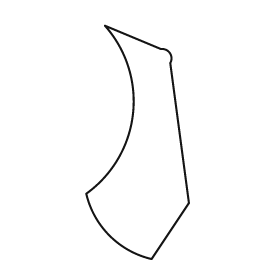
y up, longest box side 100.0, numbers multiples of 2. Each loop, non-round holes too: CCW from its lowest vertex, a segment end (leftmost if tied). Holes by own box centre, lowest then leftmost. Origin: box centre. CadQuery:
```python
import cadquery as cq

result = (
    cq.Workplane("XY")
    .moveTo(6.0, -50.0)
    .lineTo(22.0, -26.0)
    .lineTo(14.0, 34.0)
    .threePointArc((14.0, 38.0), (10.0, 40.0))
    .lineTo(-14.0, 50.0)
    .threePointArc((-2.0, 12.0), (-22.0, -22.0))
    .threePointArc((-12.0, -40.0), (6.0, -50.0))
    .close()
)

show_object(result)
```